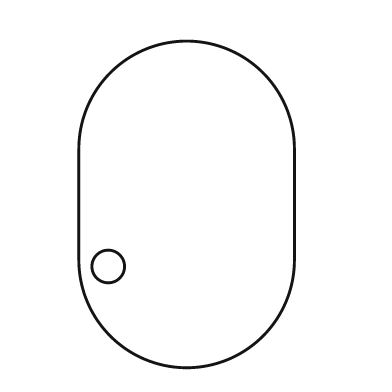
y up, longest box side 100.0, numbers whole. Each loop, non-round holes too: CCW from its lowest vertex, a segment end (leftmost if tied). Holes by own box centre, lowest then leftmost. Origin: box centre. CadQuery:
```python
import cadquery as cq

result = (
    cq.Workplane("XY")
    .moveTo(-33.0, -17.0)
    .threePointArc((0.0, -50.0), (33.0, -17.0))
    .lineTo(33.0, 17.0)
    .threePointArc((0.0, 50.0), (-33.0, 17.0))
    .close()
    .moveTo(-24.0, -19.0)
    .circle(5.0)
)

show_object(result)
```